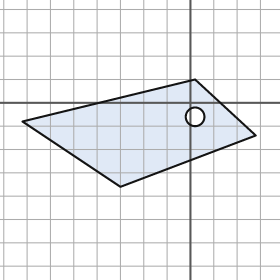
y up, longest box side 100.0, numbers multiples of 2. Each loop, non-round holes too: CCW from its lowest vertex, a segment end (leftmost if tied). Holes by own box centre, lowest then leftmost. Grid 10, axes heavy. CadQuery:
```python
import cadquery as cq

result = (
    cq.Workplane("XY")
    .moveTo(-30.0, -36.0)
    .lineTo(28.0, -14.0)
    .lineTo(2.0, 10.0)
    .lineTo(-72.0, -8.0)
    .close()
    .moveTo(2.0, -6.0)
    .circle(4.0)
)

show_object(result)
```